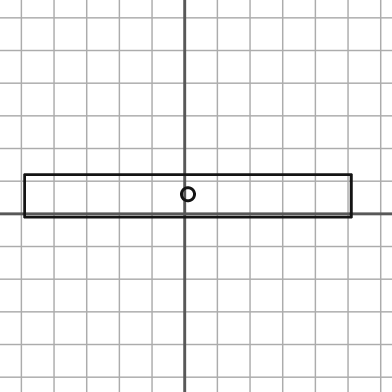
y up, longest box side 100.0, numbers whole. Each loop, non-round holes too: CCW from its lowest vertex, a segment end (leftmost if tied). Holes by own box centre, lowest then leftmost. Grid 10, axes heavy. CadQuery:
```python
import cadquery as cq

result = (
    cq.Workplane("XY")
    .moveTo(-49.0, -1.0)
    .lineTo(51.0, -1.0)
    .lineTo(51.0, 12.0)
    .lineTo(-49.0, 12.0)
    .close()
    .moveTo(1.0, 6.0)
    .circle(2.0)
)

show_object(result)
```